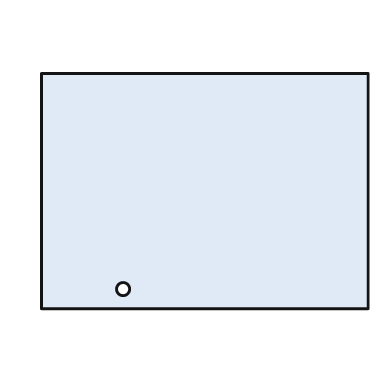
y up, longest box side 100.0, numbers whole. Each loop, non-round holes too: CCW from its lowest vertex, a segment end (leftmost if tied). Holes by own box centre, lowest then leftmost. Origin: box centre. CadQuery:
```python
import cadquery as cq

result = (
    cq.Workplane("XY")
    .moveTo(-50.0, -36.0)
    .lineTo(50.0, -36.0)
    .lineTo(50.0, 36.0)
    .lineTo(-50.0, 36.0)
    .close()
    .moveTo(-25.0, -30.0)
    .circle(2.0)
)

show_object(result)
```